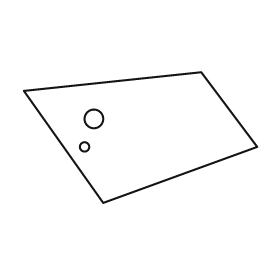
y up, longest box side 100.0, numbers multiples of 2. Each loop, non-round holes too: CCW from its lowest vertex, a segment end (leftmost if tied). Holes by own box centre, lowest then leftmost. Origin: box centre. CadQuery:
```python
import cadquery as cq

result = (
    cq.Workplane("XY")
    .moveTo(-16.0, -28.0)
    .lineTo(50.0, -4.0)
    .lineTo(26.0, 28.0)
    .lineTo(-50.0, 20.0)
    .close()
    .moveTo(-24.0, -4.0)
    .circle(2.0)
    .moveTo(-20.0, 8.0)
    .circle(4.0)
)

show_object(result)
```